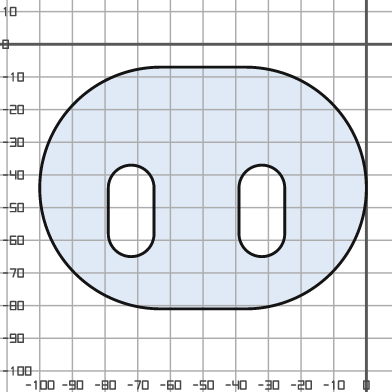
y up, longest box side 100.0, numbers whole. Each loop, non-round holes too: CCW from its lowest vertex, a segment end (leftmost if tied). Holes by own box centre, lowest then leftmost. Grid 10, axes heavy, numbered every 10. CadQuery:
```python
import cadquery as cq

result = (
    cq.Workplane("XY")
    .moveTo(-63.0, -81.0)
    .lineTo(-37.0, -81.0)
    .threePointArc((0.0, -44.0), (-37.0, -7.0))
    .lineTo(-63.0, -7.0)
    .threePointArc((-100.0, -44.0), (-63.0, -81.0))
    .close()
    .moveTo(-79.0, -58.0)
    .threePointArc((-72.0, -65.0), (-65.0, -58.0))
    .lineTo(-65.0, -44.0)
    .threePointArc((-72.0, -37.0), (-79.0, -44.0))
    .close()
    .moveTo(-39.0, -58.0)
    .threePointArc((-32.0, -65.0), (-25.0, -58.0))
    .lineTo(-25.0, -44.0)
    .threePointArc((-32.0, -37.0), (-39.0, -44.0))
    .close()
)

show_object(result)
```